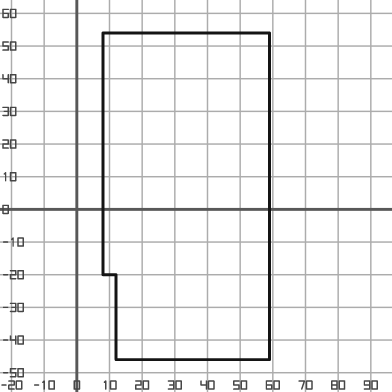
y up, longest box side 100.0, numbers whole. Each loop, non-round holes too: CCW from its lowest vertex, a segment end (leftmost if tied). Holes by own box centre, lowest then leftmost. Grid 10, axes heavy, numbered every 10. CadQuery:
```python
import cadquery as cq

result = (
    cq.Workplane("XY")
    .moveTo(12.0, -46.0)
    .lineTo(59.0, -46.0)
    .lineTo(59.0, 54.0)
    .lineTo(8.0, 54.0)
    .lineTo(8.0, -20.0)
    .lineTo(12.0, -20.0)
    .close()
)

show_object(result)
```